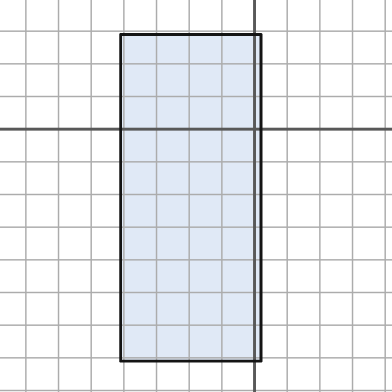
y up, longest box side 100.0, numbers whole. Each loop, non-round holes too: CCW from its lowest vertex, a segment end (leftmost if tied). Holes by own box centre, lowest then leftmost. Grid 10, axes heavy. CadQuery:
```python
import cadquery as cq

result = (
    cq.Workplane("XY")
    .moveTo(-41.0, -71.0)
    .lineTo(2.0, -71.0)
    .lineTo(2.0, 29.0)
    .lineTo(-41.0, 29.0)
    .close()
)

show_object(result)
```